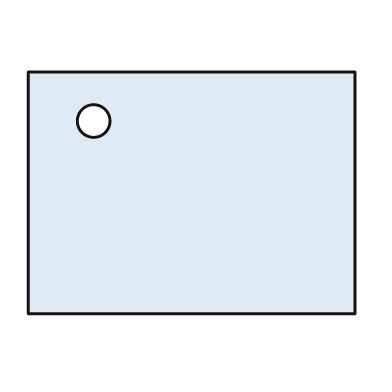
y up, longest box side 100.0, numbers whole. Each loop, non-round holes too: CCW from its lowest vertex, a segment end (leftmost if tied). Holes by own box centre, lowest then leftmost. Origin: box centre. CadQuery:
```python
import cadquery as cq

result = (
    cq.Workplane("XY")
    .moveTo(-50.0, -37.0)
    .lineTo(50.0, -37.0)
    .lineTo(50.0, 37.0)
    .lineTo(-50.0, 37.0)
    .close()
    .moveTo(-30.0, 22.0)
    .circle(5.0)
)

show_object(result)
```